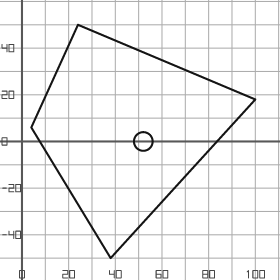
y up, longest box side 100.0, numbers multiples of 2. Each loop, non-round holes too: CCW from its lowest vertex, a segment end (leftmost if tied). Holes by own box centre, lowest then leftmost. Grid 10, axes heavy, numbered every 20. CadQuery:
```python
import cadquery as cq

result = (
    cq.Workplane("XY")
    .moveTo(38.0, -50.0)
    .lineTo(100.0, 18.0)
    .lineTo(24.0, 50.0)
    .lineTo(4.0, 6.0)
    .close()
    .moveTo(52.0, 0.0)
    .circle(4.0)
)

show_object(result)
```